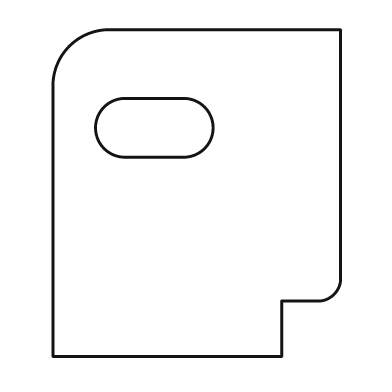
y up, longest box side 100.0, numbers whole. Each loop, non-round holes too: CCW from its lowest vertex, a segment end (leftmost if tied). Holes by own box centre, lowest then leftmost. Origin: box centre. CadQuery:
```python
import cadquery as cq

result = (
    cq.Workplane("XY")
    .moveTo(-44.0, -50.0)
    .lineTo(26.0, -50.0)
    .lineTo(26.0, -33.0)
    .lineTo(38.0, -33.0)
    .threePointArc((42.0, -31.0), (44.0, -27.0))
    .lineTo(44.0, 50.0)
    .lineTo(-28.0, 50.0)
    .threePointArc((-39.0, 45.0), (-44.0, 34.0))
    .close()
    .moveTo(-22.0, 11.0)
    .lineTo(-4.0, 11.0)
    .threePointArc((5.0, 20.0), (-4.0, 29.0))
    .lineTo(-22.0, 29.0)
    .threePointArc((-31.0, 20.0), (-22.0, 11.0))
    .close()
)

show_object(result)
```